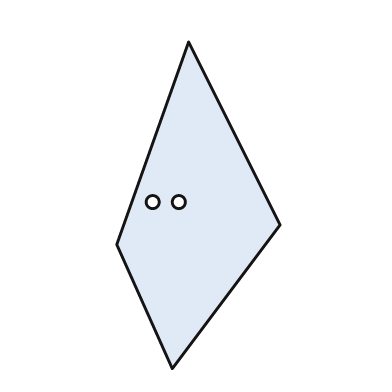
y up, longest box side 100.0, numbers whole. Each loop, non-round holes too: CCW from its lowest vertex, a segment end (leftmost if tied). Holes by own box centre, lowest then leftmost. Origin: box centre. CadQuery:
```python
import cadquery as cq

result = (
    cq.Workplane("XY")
    .moveTo(-8.0, -50.0)
    .lineTo(25.0, -6.0)
    .lineTo(-3.0, 50.0)
    .lineTo(-25.0, -12.0)
    .close()
    .moveTo(-14.0, 1.0)
    .circle(2.0)
    .moveTo(-6.0, 1.0)
    .circle(2.0)
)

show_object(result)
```